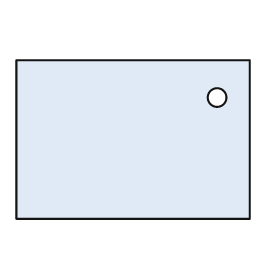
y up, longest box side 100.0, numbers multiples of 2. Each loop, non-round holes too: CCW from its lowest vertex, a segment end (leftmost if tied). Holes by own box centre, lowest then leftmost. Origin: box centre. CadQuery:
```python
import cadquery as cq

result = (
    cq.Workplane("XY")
    .moveTo(-50.0, -34.0)
    .lineTo(50.0, -34.0)
    .lineTo(50.0, 34.0)
    .lineTo(-50.0, 34.0)
    .close()
    .moveTo(36.0, 18.0)
    .circle(4.0)
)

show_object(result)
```